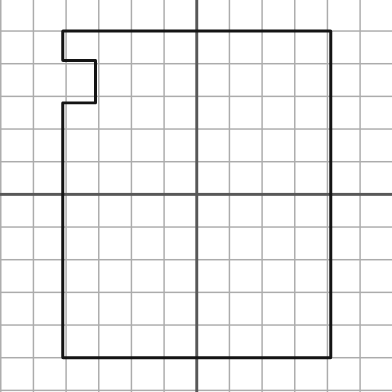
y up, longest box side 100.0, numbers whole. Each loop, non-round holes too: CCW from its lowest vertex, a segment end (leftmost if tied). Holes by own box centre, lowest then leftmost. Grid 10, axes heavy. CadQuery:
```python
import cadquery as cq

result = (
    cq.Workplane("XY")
    .moveTo(-41.0, -50.0)
    .lineTo(41.0, -50.0)
    .lineTo(41.0, 50.0)
    .lineTo(-41.0, 50.0)
    .lineTo(-41.0, 41.0)
    .lineTo(-31.0, 41.0)
    .lineTo(-31.0, 28.0)
    .lineTo(-41.0, 28.0)
    .close()
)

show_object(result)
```